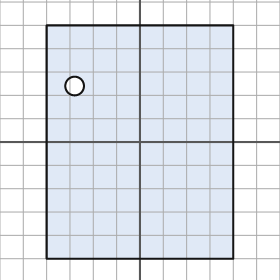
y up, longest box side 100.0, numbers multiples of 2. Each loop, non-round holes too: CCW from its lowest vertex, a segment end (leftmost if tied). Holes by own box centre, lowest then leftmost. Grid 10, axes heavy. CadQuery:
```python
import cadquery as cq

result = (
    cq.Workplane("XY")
    .moveTo(-40.0, -50.0)
    .lineTo(40.0, -50.0)
    .lineTo(40.0, 50.0)
    .lineTo(-40.0, 50.0)
    .close()
    .moveTo(-28.0, 24.0)
    .circle(4.0)
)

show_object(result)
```